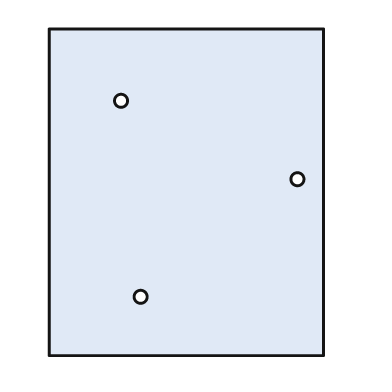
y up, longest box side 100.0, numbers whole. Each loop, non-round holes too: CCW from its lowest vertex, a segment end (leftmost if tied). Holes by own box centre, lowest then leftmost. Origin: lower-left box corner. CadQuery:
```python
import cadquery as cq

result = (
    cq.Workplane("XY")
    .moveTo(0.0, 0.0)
    .lineTo(84.0, 0.0)
    .lineTo(84.0, 100.0)
    .lineTo(0.0, 100.0)
    .close()
    .moveTo(28.0, 18.0)
    .circle(2.0)
    .moveTo(76.0, 54.0)
    .circle(2.0)
    .moveTo(22.0, 78.0)
    .circle(2.0)
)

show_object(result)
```